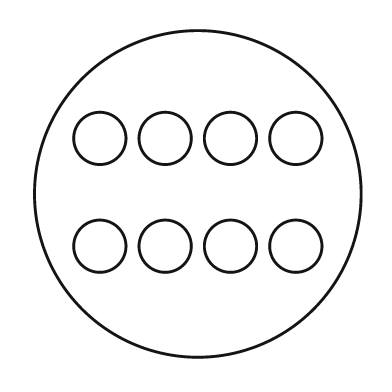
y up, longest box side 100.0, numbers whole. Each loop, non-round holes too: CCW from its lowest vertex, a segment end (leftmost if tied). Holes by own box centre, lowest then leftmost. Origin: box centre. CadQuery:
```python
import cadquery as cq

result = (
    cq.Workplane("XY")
    .moveTo(0.0, 0.0)
    .circle(50.0)
    .moveTo(-30.0, -16.0)
    .circle(8.0)
    .moveTo(-10.0, -16.0)
    .circle(8.0)
    .moveTo(10.0, -16.0)
    .circle(8.0)
    .moveTo(30.0, -16.0)
    .circle(8.0)
    .moveTo(-30.0, 17.0)
    .circle(8.0)
    .moveTo(-10.0, 17.0)
    .circle(8.0)
    .moveTo(10.0, 17.0)
    .circle(8.0)
    .moveTo(30.0, 17.0)
    .circle(8.0)
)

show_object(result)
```